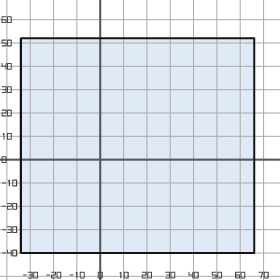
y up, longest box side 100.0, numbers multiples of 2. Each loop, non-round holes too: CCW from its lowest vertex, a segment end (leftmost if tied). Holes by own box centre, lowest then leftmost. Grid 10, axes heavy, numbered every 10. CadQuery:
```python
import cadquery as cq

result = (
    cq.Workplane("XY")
    .moveTo(-34.0, -40.0)
    .lineTo(66.0, -40.0)
    .lineTo(66.0, 52.0)
    .lineTo(-34.0, 52.0)
    .close()
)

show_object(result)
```